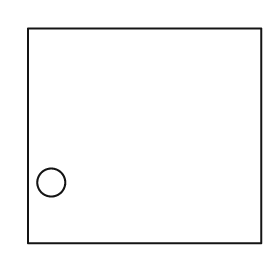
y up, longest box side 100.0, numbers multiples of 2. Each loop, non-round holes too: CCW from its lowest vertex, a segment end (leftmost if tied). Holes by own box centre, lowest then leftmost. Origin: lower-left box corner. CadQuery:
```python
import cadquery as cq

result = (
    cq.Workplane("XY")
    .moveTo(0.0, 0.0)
    .lineTo(100.0, 0.0)
    .lineTo(100.0, 92.0)
    .lineTo(0.0, 92.0)
    .close()
    .moveTo(10.0, 26.0)
    .circle(6.0)
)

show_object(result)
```